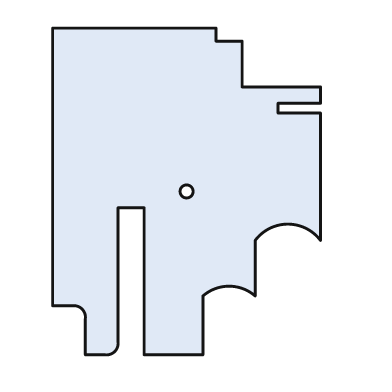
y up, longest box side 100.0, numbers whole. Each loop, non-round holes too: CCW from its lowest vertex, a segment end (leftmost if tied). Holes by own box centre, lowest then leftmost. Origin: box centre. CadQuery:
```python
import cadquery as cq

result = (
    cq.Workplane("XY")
    .moveTo(-31.0, -50.0)
    .lineTo(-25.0, -50.0)
    .threePointArc((-22.0, -49.0), (-21.0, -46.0))
    .lineTo(-21.0, -5.0)
    .lineTo(-13.0, -5.0)
    .lineTo(-13.0, -50.0)
    .lineTo(5.0, -50.0)
    .lineTo(5.0, -32.0)
    .threePointArc((13.0, -29.0), (21.0, -32.0))
    .lineTo(21.0, -15.0)
    .threePointArc((31.0, -10.0), (41.0, -15.0))
    .lineTo(41.0, 24.0)
    .lineTo(28.0, 24.0)
    .lineTo(28.0, 27.0)
    .lineTo(41.0, 27.0)
    .lineTo(41.0, 32.0)
    .lineTo(17.0, 32.0)
    .lineTo(17.0, 46.0)
    .lineTo(9.0, 46.0)
    .lineTo(9.0, 50.0)
    .lineTo(-41.0, 50.0)
    .lineTo(-41.0, -35.0)
    .lineTo(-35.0, -35.0)
    .threePointArc((-32.0, -36.0), (-31.0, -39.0))
    .close()
    .moveTo(0.0, 0.0)
    .circle(2.0)
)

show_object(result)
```